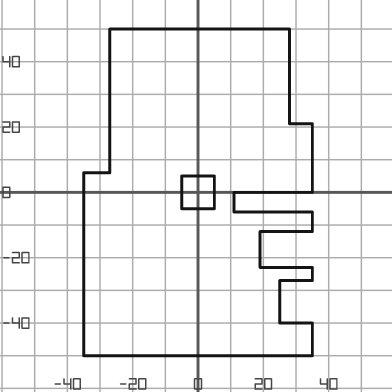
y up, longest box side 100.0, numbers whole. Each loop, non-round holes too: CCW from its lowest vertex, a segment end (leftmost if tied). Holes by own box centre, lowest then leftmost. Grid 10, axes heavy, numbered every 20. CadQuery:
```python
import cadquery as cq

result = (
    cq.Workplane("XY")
    .moveTo(-35.0, -50.0)
    .lineTo(35.0, -50.0)
    .lineTo(35.0, -40.0)
    .lineTo(25.0, -40.0)
    .lineTo(25.0, -27.0)
    .lineTo(35.0, -27.0)
    .lineTo(35.0, -23.0)
    .lineTo(19.0, -23.0)
    .lineTo(19.0, -12.0)
    .lineTo(35.0, -12.0)
    .lineTo(35.0, -6.0)
    .lineTo(11.0, -6.0)
    .lineTo(11.0, 0.0)
    .lineTo(35.0, 0.0)
    .lineTo(35.0, 21.0)
    .lineTo(28.0, 21.0)
    .lineTo(28.0, 50.0)
    .lineTo(-27.0, 50.0)
    .lineTo(-27.0, 6.0)
    .lineTo(-35.0, 6.0)
    .close()
    .moveTo(-5.0, -5.0)
    .lineTo(5.0, -5.0)
    .lineTo(5.0, 5.0)
    .lineTo(-5.0, 5.0)
    .close()
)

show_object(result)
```